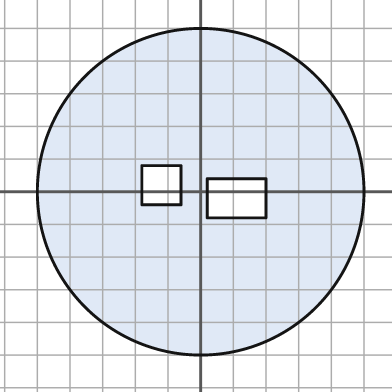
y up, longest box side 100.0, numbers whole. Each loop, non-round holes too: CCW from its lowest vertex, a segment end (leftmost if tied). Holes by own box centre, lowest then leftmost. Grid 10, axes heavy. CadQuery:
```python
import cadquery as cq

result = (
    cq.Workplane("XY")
    .moveTo(0.0, 0.0)
    .circle(50.0)
    .moveTo(2.0, -8.0)
    .lineTo(20.0, -8.0)
    .lineTo(20.0, 4.0)
    .lineTo(2.0, 4.0)
    .close()
    .moveTo(-18.0, -4.0)
    .lineTo(-6.0, -4.0)
    .lineTo(-6.0, 8.0)
    .lineTo(-18.0, 8.0)
    .close()
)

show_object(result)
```